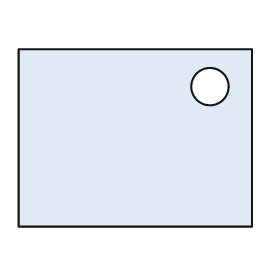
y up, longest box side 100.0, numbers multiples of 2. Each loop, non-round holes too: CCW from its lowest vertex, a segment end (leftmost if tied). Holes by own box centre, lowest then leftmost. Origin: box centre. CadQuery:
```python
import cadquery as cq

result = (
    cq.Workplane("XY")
    .moveTo(-50.0, -38.0)
    .lineTo(50.0, -38.0)
    .lineTo(50.0, 38.0)
    .lineTo(-50.0, 38.0)
    .close()
    .moveTo(32.0, 22.0)
    .circle(8.0)
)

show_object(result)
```